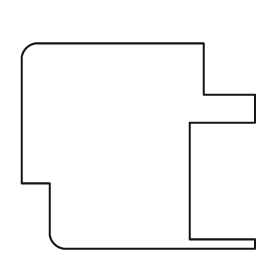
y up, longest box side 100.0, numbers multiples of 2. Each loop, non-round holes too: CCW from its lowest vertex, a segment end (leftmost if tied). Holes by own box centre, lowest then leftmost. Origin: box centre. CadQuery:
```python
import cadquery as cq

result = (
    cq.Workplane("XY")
    .moveTo(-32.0, -44.0)
    .lineTo(50.0, -44.0)
    .lineTo(50.0, -40.0)
    .lineTo(22.0, -40.0)
    .lineTo(22.0, 10.0)
    .lineTo(50.0, 10.0)
    .lineTo(50.0, 22.0)
    .lineTo(28.0, 22.0)
    .lineTo(28.0, 44.0)
    .lineTo(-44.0, 44.0)
    .threePointArc((-48.0, 42.0), (-50.0, 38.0))
    .lineTo(-50.0, -16.0)
    .lineTo(-38.0, -16.0)
    .lineTo(-38.0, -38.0)
    .threePointArc((-36.0, -42.0), (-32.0, -44.0))
    .close()
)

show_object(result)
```